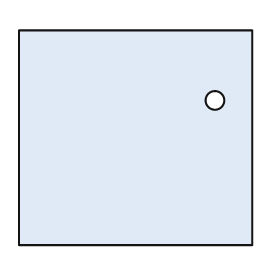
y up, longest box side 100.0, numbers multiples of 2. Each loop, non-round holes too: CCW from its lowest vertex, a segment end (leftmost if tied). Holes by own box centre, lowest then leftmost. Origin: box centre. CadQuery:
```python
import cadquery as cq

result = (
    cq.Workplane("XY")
    .moveTo(-50.0, -46.0)
    .lineTo(50.0, -46.0)
    .lineTo(50.0, 46.0)
    .lineTo(-50.0, 46.0)
    .close()
    .moveTo(34.0, 16.0)
    .circle(4.0)
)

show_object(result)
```